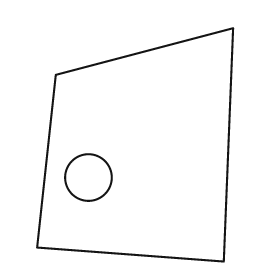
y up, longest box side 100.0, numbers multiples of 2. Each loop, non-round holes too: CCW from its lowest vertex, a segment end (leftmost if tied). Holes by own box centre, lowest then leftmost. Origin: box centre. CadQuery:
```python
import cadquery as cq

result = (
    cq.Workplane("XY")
    .moveTo(38.0, -50.0)
    .lineTo(42.0, 50.0)
    .lineTo(-34.0, 30.0)
    .lineTo(-42.0, -44.0)
    .close()
    .moveTo(-20.0, -14.0)
    .circle(10.0)
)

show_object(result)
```